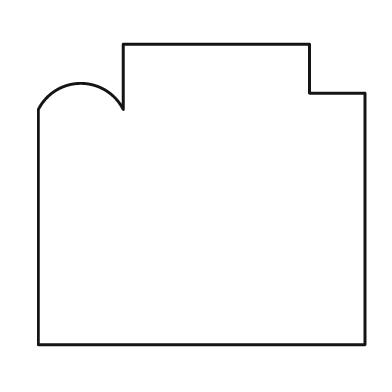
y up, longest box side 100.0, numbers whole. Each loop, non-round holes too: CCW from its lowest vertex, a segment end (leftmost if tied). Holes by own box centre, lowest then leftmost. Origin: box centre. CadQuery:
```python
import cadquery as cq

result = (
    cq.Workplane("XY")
    .moveTo(-50.0, -46.0)
    .lineTo(50.0, -46.0)
    .lineTo(50.0, 31.0)
    .lineTo(33.0, 31.0)
    .lineTo(33.0, 46.0)
    .lineTo(-24.0, 46.0)
    .lineTo(-24.0, 26.0)
    .threePointArc((-37.0, 34.0), (-50.0, 26.0))
    .close()
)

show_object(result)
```